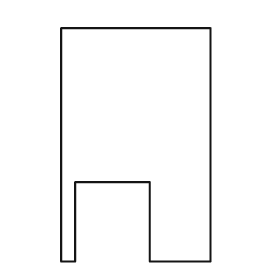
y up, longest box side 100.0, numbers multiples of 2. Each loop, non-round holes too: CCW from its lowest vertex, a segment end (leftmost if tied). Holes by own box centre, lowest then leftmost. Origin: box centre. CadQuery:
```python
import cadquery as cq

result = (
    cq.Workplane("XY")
    .moveTo(-32.0, -50.0)
    .lineTo(-26.0, -50.0)
    .lineTo(-26.0, -16.0)
    .lineTo(6.0, -16.0)
    .lineTo(6.0, -50.0)
    .lineTo(32.0, -50.0)
    .lineTo(32.0, 50.0)
    .lineTo(-32.0, 50.0)
    .close()
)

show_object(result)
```